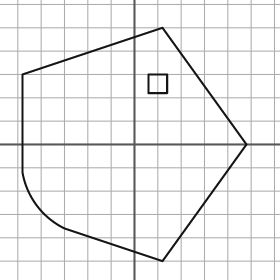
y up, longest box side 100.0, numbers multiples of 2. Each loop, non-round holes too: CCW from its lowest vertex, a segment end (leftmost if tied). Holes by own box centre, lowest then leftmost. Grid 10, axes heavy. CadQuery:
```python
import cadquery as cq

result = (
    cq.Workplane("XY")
    .moveTo(12.0, -50.0)
    .lineTo(48.0, 0.0)
    .lineTo(12.0, 50.0)
    .lineTo(-48.0, 30.0)
    .lineTo(-48.0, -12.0)
    .threePointArc((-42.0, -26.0), (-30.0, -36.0))
    .close()
    .moveTo(6.0, 22.0)
    .lineTo(14.0, 22.0)
    .lineTo(14.0, 30.0)
    .lineTo(6.0, 30.0)
    .close()
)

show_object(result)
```